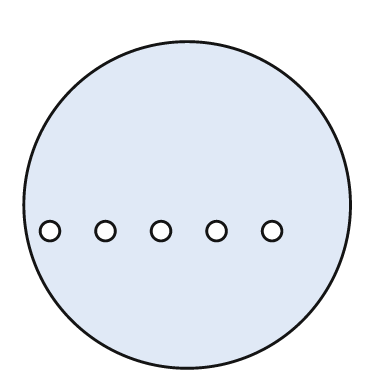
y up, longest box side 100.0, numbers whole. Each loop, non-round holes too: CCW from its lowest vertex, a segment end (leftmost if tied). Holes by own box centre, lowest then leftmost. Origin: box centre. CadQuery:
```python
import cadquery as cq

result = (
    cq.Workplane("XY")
    .moveTo(0.0, 0.0)
    .circle(50.0)
    .moveTo(-42.0, -8.0)
    .circle(3.0)
    .moveTo(-25.0, -8.0)
    .circle(3.0)
    .moveTo(-8.0, -8.0)
    .circle(3.0)
    .moveTo(9.0, -8.0)
    .circle(3.0)
    .moveTo(26.0, -8.0)
    .circle(3.0)
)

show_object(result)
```